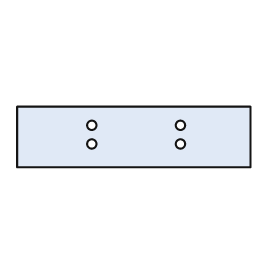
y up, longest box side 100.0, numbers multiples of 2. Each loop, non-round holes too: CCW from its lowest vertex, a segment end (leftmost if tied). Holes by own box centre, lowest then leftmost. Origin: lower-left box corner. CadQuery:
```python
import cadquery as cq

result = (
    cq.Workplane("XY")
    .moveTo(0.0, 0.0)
    .lineTo(100.0, 0.0)
    .lineTo(100.0, 26.0)
    .lineTo(0.0, 26.0)
    .close()
    .moveTo(32.0, 10.0)
    .circle(2.0)
    .moveTo(70.0, 10.0)
    .circle(2.0)
    .moveTo(32.0, 18.0)
    .circle(2.0)
    .moveTo(70.0, 18.0)
    .circle(2.0)
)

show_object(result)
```